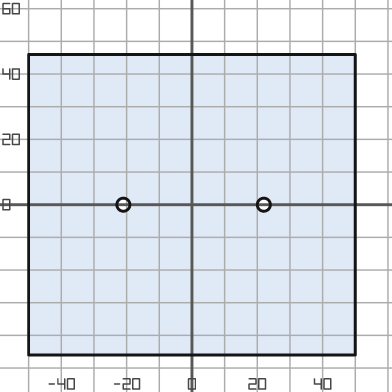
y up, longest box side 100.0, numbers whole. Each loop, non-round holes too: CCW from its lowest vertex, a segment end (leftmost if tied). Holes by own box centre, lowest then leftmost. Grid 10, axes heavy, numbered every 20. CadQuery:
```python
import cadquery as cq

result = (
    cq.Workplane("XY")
    .moveTo(-50.0, -46.0)
    .lineTo(50.0, -46.0)
    .lineTo(50.0, 46.0)
    .lineTo(-50.0, 46.0)
    .close()
    .moveTo(-21.0, 0.0)
    .circle(2.0)
    .moveTo(22.0, 0.0)
    .circle(2.0)
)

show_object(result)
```